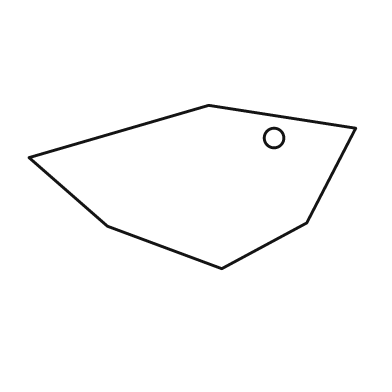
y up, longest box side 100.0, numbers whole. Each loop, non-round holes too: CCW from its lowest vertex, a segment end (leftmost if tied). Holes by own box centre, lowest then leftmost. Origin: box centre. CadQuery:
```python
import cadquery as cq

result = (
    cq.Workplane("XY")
    .moveTo(9.0, -25.0)
    .lineTo(35.0, -11.0)
    .lineTo(50.0, 18.0)
    .lineTo(5.0, 25.0)
    .lineTo(-50.0, 9.0)
    .lineTo(-26.0, -12.0)
    .close()
    .moveTo(25.0, 15.0)
    .circle(3.0)
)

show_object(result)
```